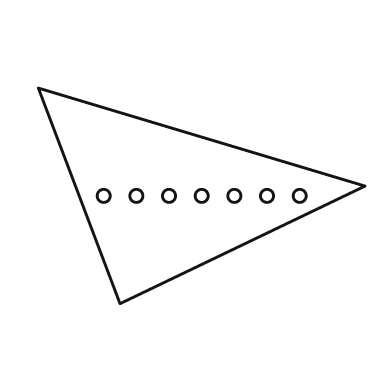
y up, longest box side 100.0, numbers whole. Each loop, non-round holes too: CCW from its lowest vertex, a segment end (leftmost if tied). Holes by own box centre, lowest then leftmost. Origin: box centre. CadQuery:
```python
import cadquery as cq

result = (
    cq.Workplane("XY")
    .moveTo(-25.0, -33.0)
    .lineTo(50.0, 3.0)
    .lineTo(-50.0, 33.0)
    .close()
    .moveTo(-30.0, 0.0)
    .circle(2.0)
    .moveTo(-20.0, 0.0)
    .circle(2.0)
    .moveTo(-10.0, 0.0)
    .circle(2.0)
    .moveTo(0.0, 0.0)
    .circle(2.0)
    .moveTo(10.0, 0.0)
    .circle(2.0)
    .moveTo(20.0, 0.0)
    .circle(2.0)
    .moveTo(30.0, 0.0)
    .circle(2.0)
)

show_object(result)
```